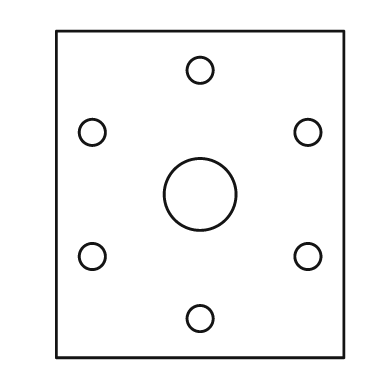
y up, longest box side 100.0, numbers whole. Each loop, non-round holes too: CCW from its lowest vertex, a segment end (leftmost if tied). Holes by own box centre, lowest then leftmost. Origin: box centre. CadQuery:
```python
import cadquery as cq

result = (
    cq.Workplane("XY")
    .moveTo(-44.0, -50.0)
    .lineTo(44.0, -50.0)
    .lineTo(44.0, 50.0)
    .lineTo(-44.0, 50.0)
    .close()
    .moveTo(0.0, -38.0)
    .circle(4.0)
    .moveTo(-33.0, -19.0)
    .circle(4.0)
    .moveTo(33.0, -19.0)
    .circle(4.0)
    .moveTo(0.0, 0.0)
    .circle(11.0)
    .moveTo(-33.0, 19.0)
    .circle(4.0)
    .moveTo(33.0, 19.0)
    .circle(4.0)
    .moveTo(0.0, 38.0)
    .circle(4.0)
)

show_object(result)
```